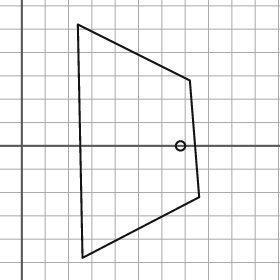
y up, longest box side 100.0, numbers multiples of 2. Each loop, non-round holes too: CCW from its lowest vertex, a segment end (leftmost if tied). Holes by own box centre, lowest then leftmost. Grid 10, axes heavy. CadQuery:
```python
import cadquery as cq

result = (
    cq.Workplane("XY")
    .moveTo(26.0, -48.0)
    .lineTo(76.0, -22.0)
    .lineTo(72.0, 28.0)
    .lineTo(24.0, 52.0)
    .close()
    .moveTo(68.0, 0.0)
    .circle(2.0)
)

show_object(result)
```